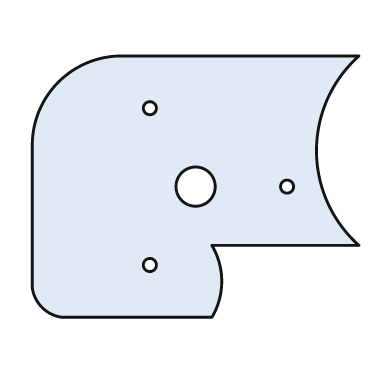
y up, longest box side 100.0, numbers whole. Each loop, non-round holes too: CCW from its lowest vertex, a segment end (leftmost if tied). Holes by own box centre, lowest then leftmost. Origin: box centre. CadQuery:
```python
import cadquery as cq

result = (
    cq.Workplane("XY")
    .moveTo(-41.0, -40.0)
    .lineTo(5.0, -40.0)
    .threePointArc((8.0, -29.0), (5.0, -18.0))
    .lineTo(50.0, -18.0)
    .threePointArc((37.0, 11.0), (50.0, 40.0))
    .lineTo(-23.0, 40.0)
    .threePointArc((-42.0, 32.0), (-50.0, 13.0))
    .lineTo(-50.0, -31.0)
    .threePointArc((-47.0, -37.0), (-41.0, -40.0))
    .close()
    .moveTo(-14.0, -24.0)
    .circle(2.0)
    .moveTo(0.0, 0.0)
    .circle(6.0)
    .moveTo(28.0, 0.0)
    .circle(2.0)
    .moveTo(-14.0, 24.0)
    .circle(2.0)
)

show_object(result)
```